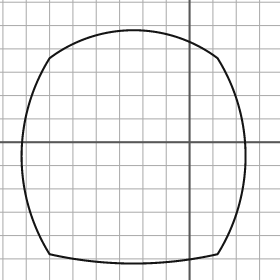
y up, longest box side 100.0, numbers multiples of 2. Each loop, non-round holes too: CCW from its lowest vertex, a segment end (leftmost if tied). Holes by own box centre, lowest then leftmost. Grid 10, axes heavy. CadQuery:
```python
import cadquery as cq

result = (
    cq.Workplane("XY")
    .moveTo(-60.0, -48.0)
    .threePointArc((-24.0, -52.0), (12.0, -48.0))
    .threePointArc((24.0, -6.0), (12.0, 36.0))
    .threePointArc((-24.0, 48.0), (-60.0, 36.0))
    .threePointArc((-72.0, -6.0), (-60.0, -48.0))
    .close()
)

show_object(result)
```